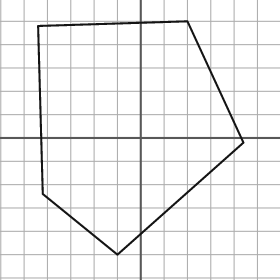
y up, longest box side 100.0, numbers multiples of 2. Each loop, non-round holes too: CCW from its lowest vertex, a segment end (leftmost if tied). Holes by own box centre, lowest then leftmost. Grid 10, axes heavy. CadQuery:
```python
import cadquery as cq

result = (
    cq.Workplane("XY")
    .moveTo(-10.0, -50.0)
    .lineTo(44.0, -2.0)
    .lineTo(20.0, 50.0)
    .lineTo(-44.0, 48.0)
    .lineTo(-42.0, -24.0)
    .close()
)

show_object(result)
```